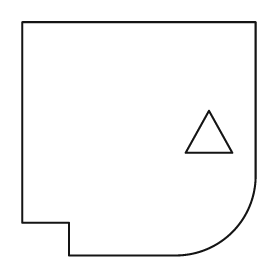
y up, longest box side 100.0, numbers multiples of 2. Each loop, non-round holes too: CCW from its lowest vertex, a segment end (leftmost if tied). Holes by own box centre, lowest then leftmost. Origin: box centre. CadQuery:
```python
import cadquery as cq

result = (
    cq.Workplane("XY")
    .moveTo(-30.0, -50.0)
    .lineTo(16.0, -50.0)
    .threePointArc((40.0, -40.0), (50.0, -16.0))
    .lineTo(50.0, 50.0)
    .lineTo(-50.0, 50.0)
    .lineTo(-50.0, -36.0)
    .lineTo(-30.0, -36.0)
    .close()
    .moveTo(20.0, -6.0)
    .lineTo(40.0, -6.0)
    .lineTo(30.0, 12.0)
    .close()
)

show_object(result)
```